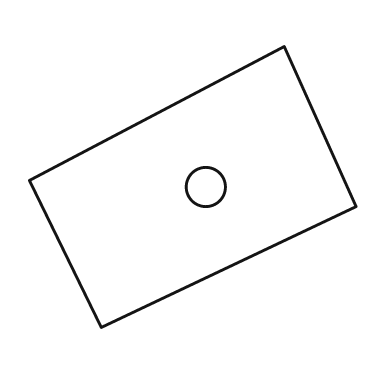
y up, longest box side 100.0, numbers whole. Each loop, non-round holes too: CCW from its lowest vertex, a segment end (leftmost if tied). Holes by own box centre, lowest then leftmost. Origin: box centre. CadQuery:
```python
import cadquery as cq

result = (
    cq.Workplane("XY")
    .moveTo(-28.0, -43.0)
    .lineTo(50.0, -6.0)
    .lineTo(28.0, 43.0)
    .lineTo(-50.0, 2.0)
    .close()
    .moveTo(4.0, 0.0)
    .circle(6.0)
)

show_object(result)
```